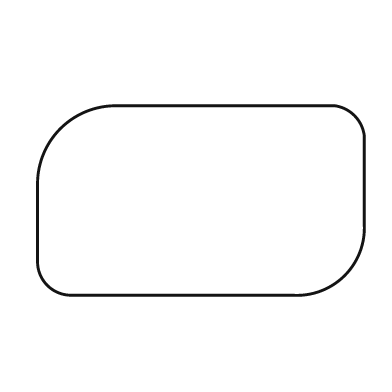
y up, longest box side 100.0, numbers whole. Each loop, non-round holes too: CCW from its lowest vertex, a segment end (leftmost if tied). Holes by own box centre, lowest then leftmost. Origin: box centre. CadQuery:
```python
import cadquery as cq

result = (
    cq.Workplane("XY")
    .moveTo(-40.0, -29.0)
    .lineTo(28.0, -29.0)
    .threePointArc((44.0, -23.0), (50.0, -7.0))
    .lineTo(50.0, 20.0)
    .threePointArc((47.0, 26.0), (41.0, 29.0))
    .lineTo(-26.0, 29.0)
    .threePointArc((-43.0, 22.0), (-50.0, 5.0))
    .lineTo(-50.0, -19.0)
    .threePointArc((-47.0, -26.0), (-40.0, -29.0))
    .close()
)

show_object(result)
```